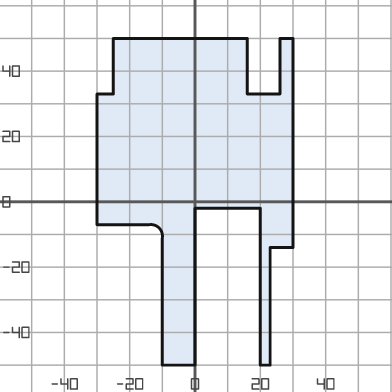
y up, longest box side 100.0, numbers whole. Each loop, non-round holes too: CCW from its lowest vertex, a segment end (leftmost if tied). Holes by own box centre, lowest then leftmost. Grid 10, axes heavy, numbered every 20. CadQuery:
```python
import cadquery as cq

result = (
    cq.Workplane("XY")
    .moveTo(-10.0, -50.0)
    .lineTo(0.0, -50.0)
    .lineTo(0.0, -2.0)
    .lineTo(20.0, -2.0)
    .lineTo(20.0, -50.0)
    .lineTo(23.0, -50.0)
    .lineTo(23.0, -14.0)
    .lineTo(30.0, -14.0)
    .lineTo(30.0, 50.0)
    .lineTo(26.0, 50.0)
    .lineTo(26.0, 33.0)
    .lineTo(16.0, 33.0)
    .lineTo(16.0, 50.0)
    .lineTo(-25.0, 50.0)
    .lineTo(-25.0, 33.0)
    .lineTo(-30.0, 33.0)
    .lineTo(-30.0, -7.0)
    .lineTo(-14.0, -7.0)
    .threePointArc((-11.0, -8.0), (-10.0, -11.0))
    .close()
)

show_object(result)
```